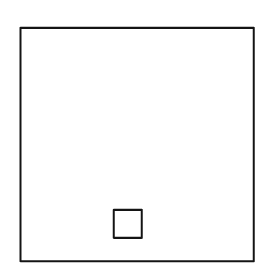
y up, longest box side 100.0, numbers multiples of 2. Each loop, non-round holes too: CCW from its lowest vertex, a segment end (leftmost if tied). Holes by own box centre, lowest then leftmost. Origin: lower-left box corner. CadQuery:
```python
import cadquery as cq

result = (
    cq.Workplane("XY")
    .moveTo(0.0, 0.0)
    .lineTo(100.0, 0.0)
    .lineTo(100.0, 100.0)
    .lineTo(0.0, 100.0)
    .close()
    .moveTo(40.0, 10.0)
    .lineTo(52.0, 10.0)
    .lineTo(52.0, 22.0)
    .lineTo(40.0, 22.0)
    .close()
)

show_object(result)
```